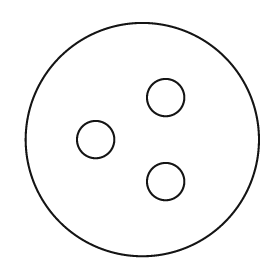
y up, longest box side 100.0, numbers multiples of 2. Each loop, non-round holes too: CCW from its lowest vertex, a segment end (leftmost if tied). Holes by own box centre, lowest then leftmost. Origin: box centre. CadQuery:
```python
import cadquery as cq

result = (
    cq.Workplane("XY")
    .moveTo(0.0, 0.0)
    .circle(50.0)
    .moveTo(10.0, -18.0)
    .circle(8.0)
    .moveTo(-20.0, 0.0)
    .circle(8.0)
    .moveTo(10.0, 18.0)
    .circle(8.0)
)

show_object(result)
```